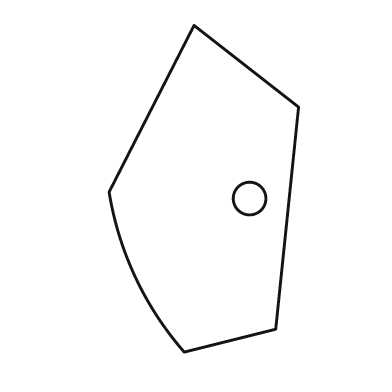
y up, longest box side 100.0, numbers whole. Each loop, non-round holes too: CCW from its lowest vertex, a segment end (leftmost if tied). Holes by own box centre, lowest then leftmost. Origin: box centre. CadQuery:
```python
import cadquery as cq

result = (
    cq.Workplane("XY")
    .moveTo(-6.0, -50.0)
    .lineTo(22.0, -43.0)
    .lineTo(29.0, 25.0)
    .lineTo(-3.0, 50.0)
    .lineTo(-29.0, -1.0)
    .threePointArc((-21.0, -27.0), (-6.0, -50.0))
    .close()
    .moveTo(14.0, -3.0)
    .circle(5.0)
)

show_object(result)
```